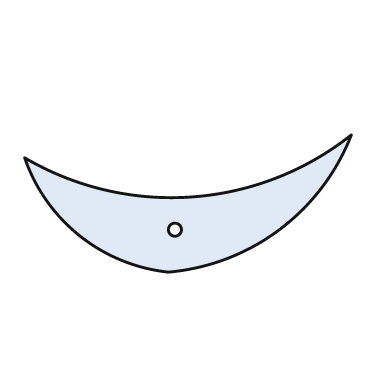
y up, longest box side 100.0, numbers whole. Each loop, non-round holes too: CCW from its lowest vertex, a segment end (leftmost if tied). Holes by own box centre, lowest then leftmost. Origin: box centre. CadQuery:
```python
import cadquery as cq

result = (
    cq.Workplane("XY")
    .moveTo(-6.0, -21.0)
    .threePointArc((28.0, -8.0), (50.0, 21.0))
    .threePointArc((1.0, 2.0), (-50.0, 14.0))
    .threePointArc((-33.0, -10.0), (-6.0, -21.0))
    .close()
    .moveTo(-4.0, -8.0)
    .circle(2.0)
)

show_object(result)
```